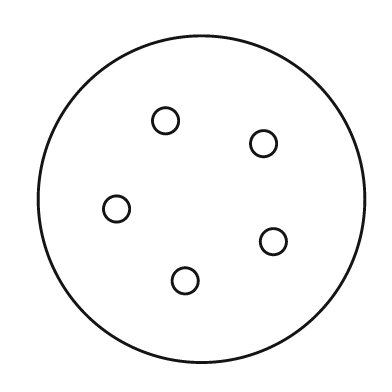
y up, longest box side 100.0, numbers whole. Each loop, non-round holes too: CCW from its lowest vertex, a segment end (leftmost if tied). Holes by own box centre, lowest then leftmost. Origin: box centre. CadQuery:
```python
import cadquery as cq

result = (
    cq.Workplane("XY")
    .moveTo(0.0, 0.0)
    .circle(50.0)
    .moveTo(-5.0, -25.0)
    .circle(4.0)
    .moveTo(22.0, -13.0)
    .circle(4.0)
    .moveTo(-26.0, -3.0)
    .circle(4.0)
    .moveTo(19.0, 17.0)
    .circle(4.0)
    .moveTo(-11.0, 24.0)
    .circle(4.0)
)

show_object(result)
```